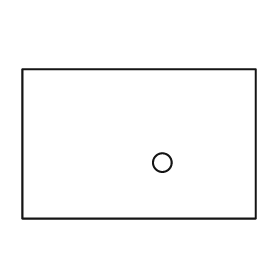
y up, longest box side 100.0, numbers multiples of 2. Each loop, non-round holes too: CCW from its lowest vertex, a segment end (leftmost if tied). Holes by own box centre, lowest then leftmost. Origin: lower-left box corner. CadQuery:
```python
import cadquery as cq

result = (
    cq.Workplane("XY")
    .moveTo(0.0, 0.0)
    .lineTo(100.0, 0.0)
    .lineTo(100.0, 64.0)
    .lineTo(0.0, 64.0)
    .close()
    .moveTo(60.0, 24.0)
    .circle(4.0)
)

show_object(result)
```